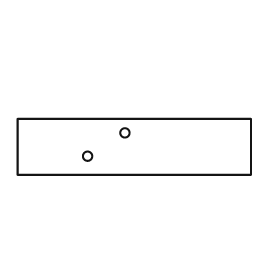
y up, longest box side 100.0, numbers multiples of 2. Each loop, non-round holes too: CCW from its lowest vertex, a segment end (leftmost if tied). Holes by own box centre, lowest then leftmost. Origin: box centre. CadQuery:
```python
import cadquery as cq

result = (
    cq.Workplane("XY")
    .moveTo(-50.0, -12.0)
    .lineTo(50.0, -12.0)
    .lineTo(50.0, 12.0)
    .lineTo(-50.0, 12.0)
    .close()
    .moveTo(-20.0, -4.0)
    .circle(2.0)
    .moveTo(-4.0, 6.0)
    .circle(2.0)
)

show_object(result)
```